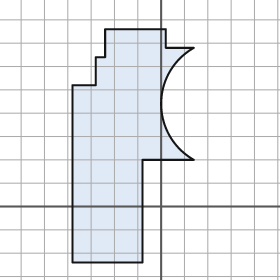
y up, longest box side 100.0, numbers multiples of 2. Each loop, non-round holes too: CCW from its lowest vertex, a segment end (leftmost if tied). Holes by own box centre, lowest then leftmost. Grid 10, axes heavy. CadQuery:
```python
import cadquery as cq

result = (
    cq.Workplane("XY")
    .moveTo(-38.0, -24.0)
    .lineTo(-8.0, -24.0)
    .lineTo(-8.0, 20.0)
    .lineTo(14.0, 20.0)
    .threePointArc((0.0, 44.0), (14.0, 68.0))
    .lineTo(2.0, 68.0)
    .lineTo(2.0, 76.0)
    .lineTo(-24.0, 76.0)
    .lineTo(-24.0, 64.0)
    .lineTo(-28.0, 64.0)
    .lineTo(-28.0, 52.0)
    .lineTo(-38.0, 52.0)
    .close()
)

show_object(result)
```